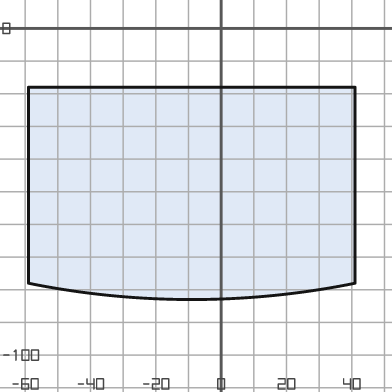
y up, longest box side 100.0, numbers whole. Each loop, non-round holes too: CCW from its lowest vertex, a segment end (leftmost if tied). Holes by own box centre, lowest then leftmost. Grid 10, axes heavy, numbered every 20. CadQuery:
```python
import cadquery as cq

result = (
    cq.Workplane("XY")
    .moveTo(-59.0, -78.0)
    .threePointArc((-9.0, -83.0), (41.0, -78.0))
    .lineTo(41.0, -18.0)
    .lineTo(-59.0, -18.0)
    .close()
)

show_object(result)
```